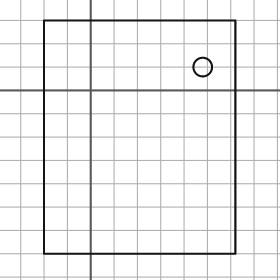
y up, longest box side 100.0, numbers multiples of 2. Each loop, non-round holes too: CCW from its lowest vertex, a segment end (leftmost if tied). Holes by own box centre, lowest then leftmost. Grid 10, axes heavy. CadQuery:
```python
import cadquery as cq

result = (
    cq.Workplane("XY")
    .moveTo(-20.0, -70.0)
    .lineTo(62.0, -70.0)
    .lineTo(62.0, 30.0)
    .lineTo(-20.0, 30.0)
    .close()
    .moveTo(48.0, 10.0)
    .circle(4.0)
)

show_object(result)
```